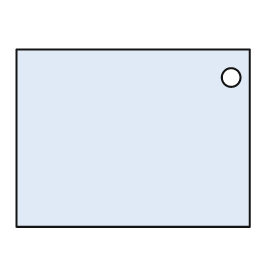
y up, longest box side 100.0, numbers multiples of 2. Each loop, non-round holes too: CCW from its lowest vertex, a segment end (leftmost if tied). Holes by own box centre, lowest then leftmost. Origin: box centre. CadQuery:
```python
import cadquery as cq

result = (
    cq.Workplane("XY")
    .moveTo(-50.0, -38.0)
    .lineTo(50.0, -38.0)
    .lineTo(50.0, 38.0)
    .lineTo(-50.0, 38.0)
    .close()
    .moveTo(42.0, 26.0)
    .circle(4.0)
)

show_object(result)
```